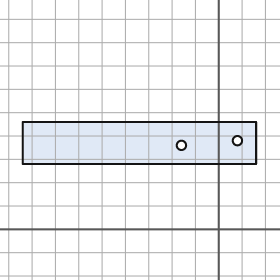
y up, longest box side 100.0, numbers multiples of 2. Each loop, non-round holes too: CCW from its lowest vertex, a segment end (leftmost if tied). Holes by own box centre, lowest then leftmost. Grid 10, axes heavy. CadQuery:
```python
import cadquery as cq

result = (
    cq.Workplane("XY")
    .moveTo(-84.0, 28.0)
    .lineTo(16.0, 28.0)
    .lineTo(16.0, 46.0)
    .lineTo(-84.0, 46.0)
    .close()
    .moveTo(-16.0, 36.0)
    .circle(2.0)
    .moveTo(8.0, 38.0)
    .circle(2.0)
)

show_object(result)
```